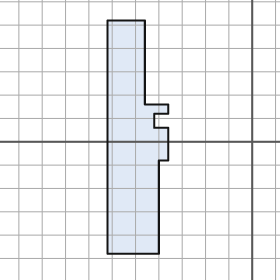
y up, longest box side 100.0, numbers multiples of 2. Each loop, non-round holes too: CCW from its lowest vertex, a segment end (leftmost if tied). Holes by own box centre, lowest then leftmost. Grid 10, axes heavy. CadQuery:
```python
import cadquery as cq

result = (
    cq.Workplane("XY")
    .moveTo(-62.0, -48.0)
    .lineTo(-40.0, -48.0)
    .lineTo(-40.0, -8.0)
    .lineTo(-36.0, -8.0)
    .lineTo(-36.0, 6.0)
    .lineTo(-42.0, 6.0)
    .lineTo(-42.0, 12.0)
    .lineTo(-36.0, 12.0)
    .lineTo(-36.0, 16.0)
    .lineTo(-46.0, 16.0)
    .lineTo(-46.0, 52.0)
    .lineTo(-62.0, 52.0)
    .close()
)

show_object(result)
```